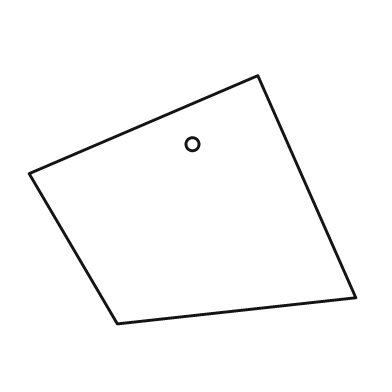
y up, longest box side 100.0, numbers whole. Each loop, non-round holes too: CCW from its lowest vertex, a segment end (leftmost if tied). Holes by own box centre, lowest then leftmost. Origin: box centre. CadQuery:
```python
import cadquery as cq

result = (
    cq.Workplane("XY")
    .moveTo(-23.0, -38.0)
    .lineTo(50.0, -30.0)
    .lineTo(20.0, 38.0)
    .lineTo(-50.0, 8.0)
    .close()
    .moveTo(0.0, 17.0)
    .circle(2.0)
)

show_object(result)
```